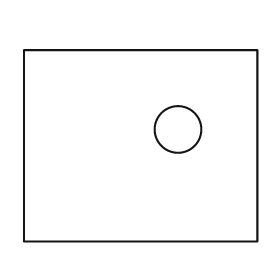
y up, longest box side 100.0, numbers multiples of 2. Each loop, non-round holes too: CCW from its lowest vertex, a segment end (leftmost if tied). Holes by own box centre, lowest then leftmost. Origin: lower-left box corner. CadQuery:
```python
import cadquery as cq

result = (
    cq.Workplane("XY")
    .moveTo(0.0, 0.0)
    .lineTo(100.0, 0.0)
    .lineTo(100.0, 82.0)
    .lineTo(0.0, 82.0)
    .close()
    .moveTo(66.0, 48.0)
    .circle(10.0)
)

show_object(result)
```